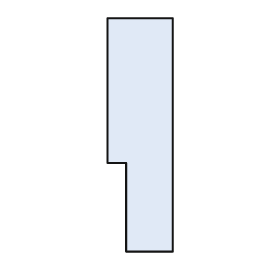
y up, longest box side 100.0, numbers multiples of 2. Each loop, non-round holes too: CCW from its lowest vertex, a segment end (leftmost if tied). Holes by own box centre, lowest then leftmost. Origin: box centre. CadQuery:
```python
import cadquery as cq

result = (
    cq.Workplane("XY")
    .moveTo(-6.0, -50.0)
    .lineTo(14.0, -50.0)
    .lineTo(14.0, 50.0)
    .lineTo(-14.0, 50.0)
    .lineTo(-14.0, -12.0)
    .lineTo(-6.0, -12.0)
    .close()
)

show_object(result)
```